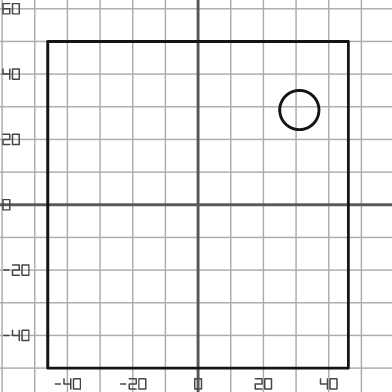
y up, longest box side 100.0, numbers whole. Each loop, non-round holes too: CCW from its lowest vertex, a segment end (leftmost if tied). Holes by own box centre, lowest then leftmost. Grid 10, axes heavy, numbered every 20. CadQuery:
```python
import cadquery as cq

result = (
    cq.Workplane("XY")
    .moveTo(-46.0, -50.0)
    .lineTo(46.0, -50.0)
    .lineTo(46.0, 50.0)
    .lineTo(-46.0, 50.0)
    .close()
    .moveTo(31.0, 29.0)
    .circle(6.0)
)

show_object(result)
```